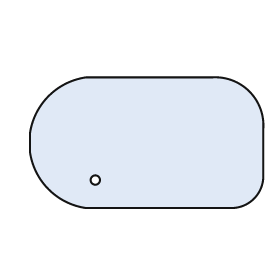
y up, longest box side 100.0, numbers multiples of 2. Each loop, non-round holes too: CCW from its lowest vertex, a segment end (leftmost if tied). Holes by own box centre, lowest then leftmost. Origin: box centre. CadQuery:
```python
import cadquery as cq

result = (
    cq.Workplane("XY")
    .moveTo(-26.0, -28.0)
    .lineTo(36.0, -28.0)
    .threePointArc((46.0, -24.0), (50.0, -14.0))
    .lineTo(50.0, 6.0)
    .threePointArc((44.0, 22.0), (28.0, 28.0))
    .lineTo(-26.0, 28.0)
    .threePointArc((-42.0, 20.0), (-50.0, 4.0))
    .lineTo(-50.0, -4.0)
    .threePointArc((-42.0, -20.0), (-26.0, -28.0))
    .close()
    .moveTo(-22.0, -16.0)
    .circle(2.0)
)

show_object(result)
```